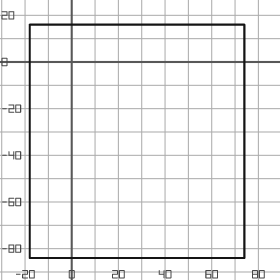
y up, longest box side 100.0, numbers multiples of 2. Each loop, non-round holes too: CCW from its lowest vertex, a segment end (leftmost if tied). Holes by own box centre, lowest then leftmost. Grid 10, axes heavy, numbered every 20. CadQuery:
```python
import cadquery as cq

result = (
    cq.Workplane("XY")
    .moveTo(-18.0, -84.0)
    .lineTo(74.0, -84.0)
    .lineTo(74.0, 16.0)
    .lineTo(-18.0, 16.0)
    .close()
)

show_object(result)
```